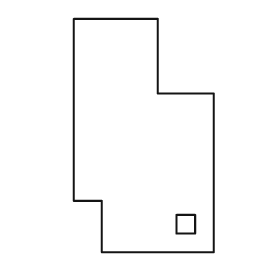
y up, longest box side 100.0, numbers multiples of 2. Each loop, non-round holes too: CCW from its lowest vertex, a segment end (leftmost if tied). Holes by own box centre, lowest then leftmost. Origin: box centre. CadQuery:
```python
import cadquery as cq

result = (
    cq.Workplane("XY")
    .moveTo(-18.0, -50.0)
    .lineTo(30.0, -50.0)
    .lineTo(30.0, 18.0)
    .lineTo(6.0, 18.0)
    .lineTo(6.0, 50.0)
    .lineTo(-30.0, 50.0)
    .lineTo(-30.0, -28.0)
    .lineTo(-18.0, -28.0)
    .close()
    .moveTo(14.0, -42.0)
    .lineTo(22.0, -42.0)
    .lineTo(22.0, -34.0)
    .lineTo(14.0, -34.0)
    .close()
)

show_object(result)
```